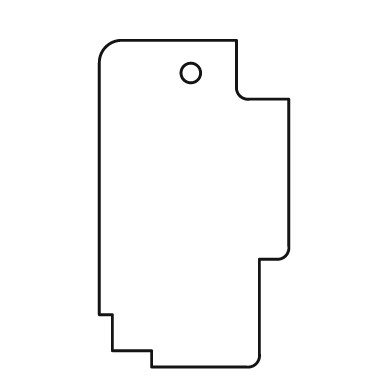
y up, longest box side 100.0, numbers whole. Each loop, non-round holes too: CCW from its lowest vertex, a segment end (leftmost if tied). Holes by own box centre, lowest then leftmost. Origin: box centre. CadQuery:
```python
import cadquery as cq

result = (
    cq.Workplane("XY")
    .moveTo(-13.0, -50.0)
    .lineTo(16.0, -50.0)
    .threePointArc((19.0, -49.0), (20.0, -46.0))
    .lineTo(20.0, -17.0)
    .lineTo(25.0, -17.0)
    .threePointArc((28.0, -16.0), (29.0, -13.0))
    .lineTo(29.0, 32.0)
    .lineTo(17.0, 32.0)
    .threePointArc((14.0, 33.0), (13.0, 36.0))
    .lineTo(13.0, 50.0)
    .lineTo(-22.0, 50.0)
    .threePointArc((-27.0, 48.0), (-29.0, 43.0))
    .lineTo(-29.0, -34.0)
    .lineTo(-25.0, -34.0)
    .lineTo(-25.0, -45.0)
    .lineTo(-13.0, -45.0)
    .close()
    .moveTo(-1.0, 40.0)
    .circle(3.0)
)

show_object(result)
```